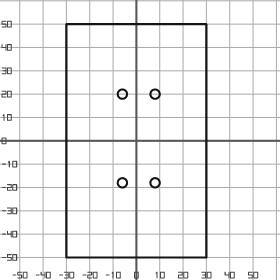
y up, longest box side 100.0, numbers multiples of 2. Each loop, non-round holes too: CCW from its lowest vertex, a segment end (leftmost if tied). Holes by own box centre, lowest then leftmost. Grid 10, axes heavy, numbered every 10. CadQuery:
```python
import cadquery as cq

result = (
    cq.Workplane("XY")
    .moveTo(-30.0, -50.0)
    .lineTo(30.0, -50.0)
    .lineTo(30.0, 50.0)
    .lineTo(-30.0, 50.0)
    .close()
    .moveTo(-6.0, -18.0)
    .circle(2.0)
    .moveTo(8.0, -18.0)
    .circle(2.0)
    .moveTo(-6.0, 20.0)
    .circle(2.0)
    .moveTo(8.0, 20.0)
    .circle(2.0)
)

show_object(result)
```